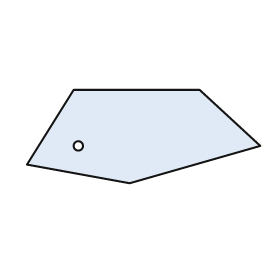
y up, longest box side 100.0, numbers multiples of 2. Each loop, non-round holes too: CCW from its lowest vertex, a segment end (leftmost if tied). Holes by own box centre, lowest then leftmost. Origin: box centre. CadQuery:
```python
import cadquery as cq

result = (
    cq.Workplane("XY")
    .moveTo(-6.0, -20.0)
    .lineTo(50.0, -4.0)
    .lineTo(24.0, 20.0)
    .lineTo(-30.0, 20.0)
    .lineTo(-50.0, -12.0)
    .close()
    .moveTo(-28.0, -4.0)
    .circle(2.0)
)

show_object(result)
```